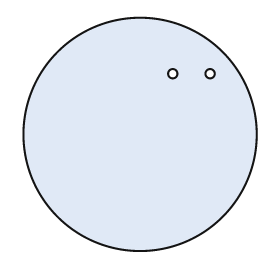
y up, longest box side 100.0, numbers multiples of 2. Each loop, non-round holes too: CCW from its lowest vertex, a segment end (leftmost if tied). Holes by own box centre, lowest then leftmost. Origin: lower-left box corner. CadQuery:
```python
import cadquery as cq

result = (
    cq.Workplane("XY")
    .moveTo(50.0, 50.0)
    .circle(50.0)
    .moveTo(64.0, 76.0)
    .circle(2.0)
    .moveTo(80.0, 76.0)
    .circle(2.0)
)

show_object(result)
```